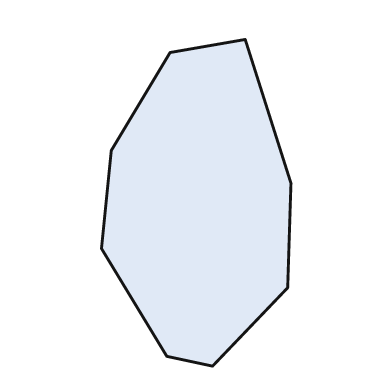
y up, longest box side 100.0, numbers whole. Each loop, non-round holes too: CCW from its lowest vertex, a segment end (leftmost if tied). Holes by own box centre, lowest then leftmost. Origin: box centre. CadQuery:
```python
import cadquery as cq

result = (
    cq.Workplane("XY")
    .moveTo(5.0, -50.0)
    .lineTo(28.0, -26.0)
    .lineTo(29.0, 6.0)
    .lineTo(15.0, 50.0)
    .lineTo(-8.0, 46.0)
    .lineTo(-26.0, 16.0)
    .lineTo(-29.0, -14.0)
    .lineTo(-9.0, -47.0)
    .close()
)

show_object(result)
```